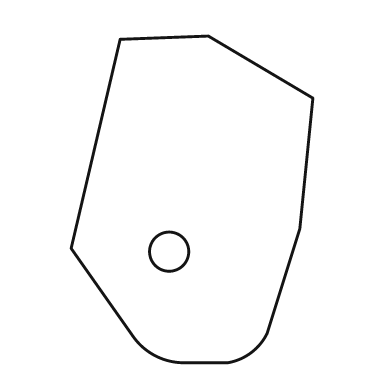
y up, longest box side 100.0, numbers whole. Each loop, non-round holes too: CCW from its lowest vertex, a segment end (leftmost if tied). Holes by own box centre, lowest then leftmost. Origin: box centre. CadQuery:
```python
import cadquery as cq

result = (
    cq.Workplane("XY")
    .moveTo(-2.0, -50.0)
    .lineTo(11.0, -50.0)
    .threePointArc((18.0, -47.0), (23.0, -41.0))
    .lineTo(33.0, -9.0)
    .lineTo(37.0, 31.0)
    .lineTo(5.0, 50.0)
    .lineTo(-22.0, 49.0)
    .lineTo(-37.0, -15.0)
    .lineTo(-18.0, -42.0)
    .threePointArc((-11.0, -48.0), (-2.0, -50.0))
    .close()
    .moveTo(-7.0, -16.0)
    .circle(6.0)
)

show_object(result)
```